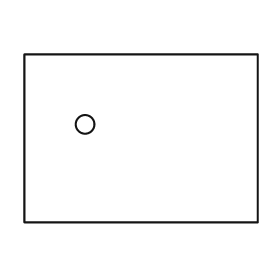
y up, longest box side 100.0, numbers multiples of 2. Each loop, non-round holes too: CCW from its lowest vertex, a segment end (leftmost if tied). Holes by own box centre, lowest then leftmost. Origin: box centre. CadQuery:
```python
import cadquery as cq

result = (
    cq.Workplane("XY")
    .moveTo(-50.0, -36.0)
    .lineTo(50.0, -36.0)
    .lineTo(50.0, 36.0)
    .lineTo(-50.0, 36.0)
    .close()
    .moveTo(-24.0, 6.0)
    .circle(4.0)
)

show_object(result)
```